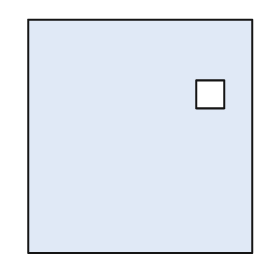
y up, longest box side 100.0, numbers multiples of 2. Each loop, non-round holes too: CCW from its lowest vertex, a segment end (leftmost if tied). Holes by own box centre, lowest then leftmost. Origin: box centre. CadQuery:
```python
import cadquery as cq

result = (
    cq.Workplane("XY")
    .moveTo(-48.0, -50.0)
    .lineTo(48.0, -50.0)
    .lineTo(48.0, 50.0)
    .lineTo(-48.0, 50.0)
    .close()
    .moveTo(24.0, 12.0)
    .lineTo(36.0, 12.0)
    .lineTo(36.0, 24.0)
    .lineTo(24.0, 24.0)
    .close()
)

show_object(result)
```